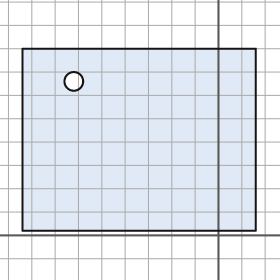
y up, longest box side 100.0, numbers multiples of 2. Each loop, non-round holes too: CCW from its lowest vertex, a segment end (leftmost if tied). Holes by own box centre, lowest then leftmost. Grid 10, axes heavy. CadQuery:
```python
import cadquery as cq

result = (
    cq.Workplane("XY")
    .moveTo(-84.0, 2.0)
    .lineTo(16.0, 2.0)
    .lineTo(16.0, 80.0)
    .lineTo(-84.0, 80.0)
    .close()
    .moveTo(-62.0, 66.0)
    .circle(4.0)
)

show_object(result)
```